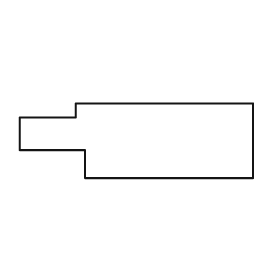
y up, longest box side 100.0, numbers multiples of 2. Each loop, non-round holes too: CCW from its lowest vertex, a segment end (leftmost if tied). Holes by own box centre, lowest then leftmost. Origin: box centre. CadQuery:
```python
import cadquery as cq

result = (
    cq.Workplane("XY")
    .moveTo(-22.0, -16.0)
    .lineTo(50.0, -16.0)
    .lineTo(50.0, 16.0)
    .lineTo(-26.0, 16.0)
    .lineTo(-26.0, 10.0)
    .lineTo(-50.0, 10.0)
    .lineTo(-50.0, -4.0)
    .lineTo(-22.0, -4.0)
    .close()
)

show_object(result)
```